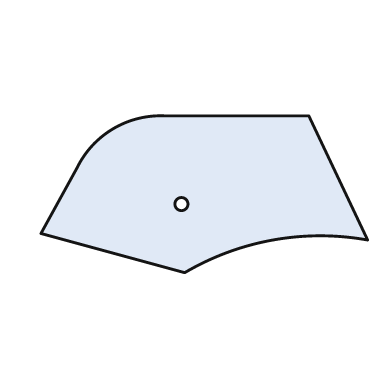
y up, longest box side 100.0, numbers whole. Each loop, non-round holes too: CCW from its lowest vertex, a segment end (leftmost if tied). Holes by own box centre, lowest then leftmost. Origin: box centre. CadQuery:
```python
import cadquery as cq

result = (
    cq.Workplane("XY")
    .moveTo(-6.0, -24.0)
    .threePointArc((21.0, -14.0), (50.0, -14.0))
    .lineTo(32.0, 24.0)
    .lineTo(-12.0, 24.0)
    .threePointArc((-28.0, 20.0), (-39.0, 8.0))
    .lineTo(-50.0, -12.0)
    .close()
    .moveTo(-7.0, -3.0)
    .circle(2.0)
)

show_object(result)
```